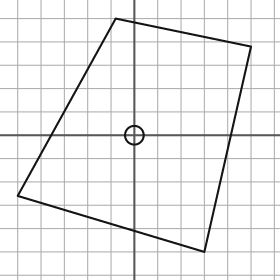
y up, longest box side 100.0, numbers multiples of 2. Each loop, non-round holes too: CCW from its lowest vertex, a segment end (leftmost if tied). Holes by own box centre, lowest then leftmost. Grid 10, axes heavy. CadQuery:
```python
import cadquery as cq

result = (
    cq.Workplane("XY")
    .moveTo(30.0, -50.0)
    .lineTo(50.0, 38.0)
    .lineTo(-8.0, 50.0)
    .lineTo(-50.0, -26.0)
    .close()
    .moveTo(0.0, 0.0)
    .circle(4.0)
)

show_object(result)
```